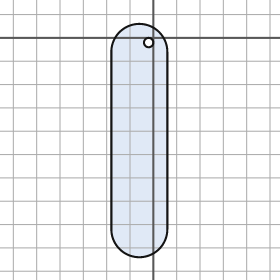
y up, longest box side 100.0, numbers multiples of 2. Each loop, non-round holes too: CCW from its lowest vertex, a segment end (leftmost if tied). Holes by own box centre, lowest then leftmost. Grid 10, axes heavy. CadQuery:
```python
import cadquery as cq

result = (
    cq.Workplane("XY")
    .moveTo(-18.0, -82.0)
    .threePointArc((-6.0, -94.0), (6.0, -82.0))
    .lineTo(6.0, -6.0)
    .threePointArc((-6.0, 6.0), (-18.0, -6.0))
    .close()
    .moveTo(-2.0, -2.0)
    .circle(2.0)
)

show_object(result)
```